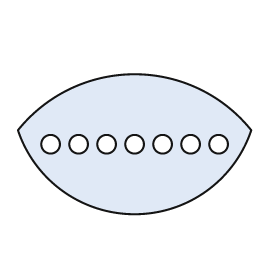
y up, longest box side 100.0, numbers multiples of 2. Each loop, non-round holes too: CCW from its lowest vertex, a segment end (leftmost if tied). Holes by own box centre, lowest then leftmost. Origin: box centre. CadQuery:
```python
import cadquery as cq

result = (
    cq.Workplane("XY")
    .moveTo(-50.0, 6.0)
    .threePointArc((0.0, -30.0), (50.0, 6.0))
    .threePointArc((0.0, 30.0), (-50.0, 6.0))
    .close()
    .moveTo(-36.0, 0.0)
    .circle(4.0)
    .moveTo(-24.0, 0.0)
    .circle(4.0)
    .moveTo(-12.0, 0.0)
    .circle(4.0)
    .moveTo(0.0, 0.0)
    .circle(4.0)
    .moveTo(12.0, 0.0)
    .circle(4.0)
    .moveTo(24.0, 0.0)
    .circle(4.0)
    .moveTo(36.0, 0.0)
    .circle(4.0)
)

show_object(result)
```